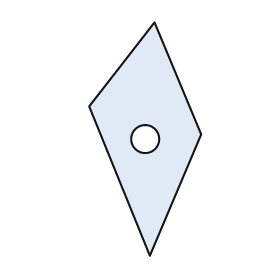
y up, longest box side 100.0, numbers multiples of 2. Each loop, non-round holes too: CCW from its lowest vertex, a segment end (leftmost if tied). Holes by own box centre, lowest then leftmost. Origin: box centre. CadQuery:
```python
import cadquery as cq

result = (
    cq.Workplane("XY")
    .moveTo(2.0, -50.0)
    .lineTo(24.0, 2.0)
    .lineTo(4.0, 50.0)
    .lineTo(-24.0, 14.0)
    .close()
    .moveTo(0.0, 0.0)
    .circle(6.0)
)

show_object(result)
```